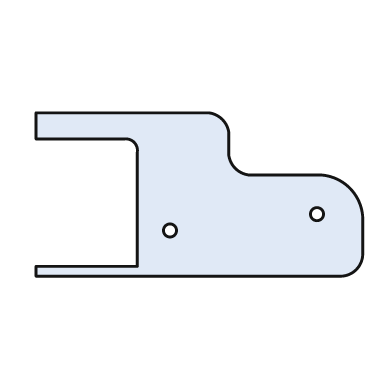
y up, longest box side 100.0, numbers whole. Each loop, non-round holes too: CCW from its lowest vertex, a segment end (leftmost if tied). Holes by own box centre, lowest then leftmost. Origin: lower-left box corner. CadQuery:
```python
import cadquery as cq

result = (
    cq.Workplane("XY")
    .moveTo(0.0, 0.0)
    .lineTo(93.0, 0.0)
    .threePointArc((98.0, 2.0), (100.0, 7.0))
    .lineTo(100.0, 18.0)
    .threePointArc((96.0, 27.0), (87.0, 31.0))
    .lineTo(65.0, 31.0)
    .threePointArc((61.0, 33.0), (59.0, 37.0))
    .lineTo(59.0, 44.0)
    .threePointArc((57.0, 48.0), (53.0, 50.0))
    .lineTo(0.0, 50.0)
    .lineTo(0.0, 42.0)
    .lineTo(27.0, 42.0)
    .threePointArc((30.0, 41.0), (31.0, 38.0))
    .lineTo(31.0, 3.0)
    .lineTo(0.0, 3.0)
    .close()
    .moveTo(41.0, 14.0)
    .circle(2.0)
    .moveTo(86.0, 19.0)
    .circle(2.0)
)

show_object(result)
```